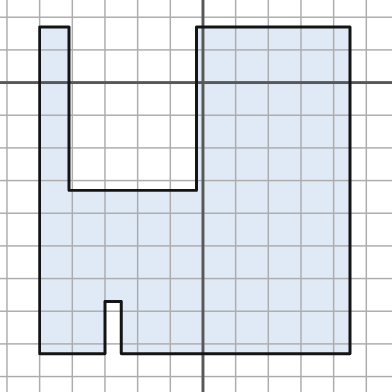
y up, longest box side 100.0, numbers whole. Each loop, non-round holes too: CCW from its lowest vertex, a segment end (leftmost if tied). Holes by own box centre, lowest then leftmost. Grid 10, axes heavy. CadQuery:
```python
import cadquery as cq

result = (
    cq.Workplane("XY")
    .moveTo(-50.0, -83.0)
    .lineTo(-30.0, -83.0)
    .lineTo(-30.0, -67.0)
    .lineTo(-25.0, -67.0)
    .lineTo(-25.0, -83.0)
    .lineTo(45.0, -83.0)
    .lineTo(45.0, 17.0)
    .lineTo(-2.0, 17.0)
    .lineTo(-2.0, -33.0)
    .lineTo(-41.0, -33.0)
    .lineTo(-41.0, 17.0)
    .lineTo(-50.0, 17.0)
    .close()
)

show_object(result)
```